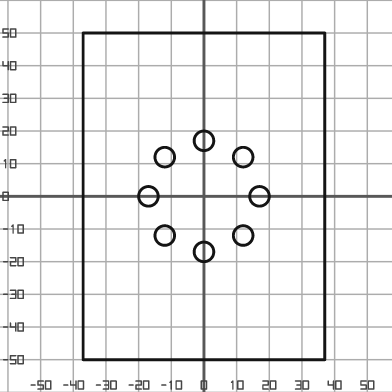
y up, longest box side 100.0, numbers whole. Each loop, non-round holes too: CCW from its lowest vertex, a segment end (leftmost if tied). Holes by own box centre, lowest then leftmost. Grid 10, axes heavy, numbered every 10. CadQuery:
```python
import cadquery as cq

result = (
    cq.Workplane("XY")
    .moveTo(-37.0, -50.0)
    .lineTo(37.0, -50.0)
    .lineTo(37.0, 50.0)
    .lineTo(-37.0, 50.0)
    .close()
    .moveTo(0.0, -17.0)
    .circle(3.0)
    .moveTo(-12.0, -12.0)
    .circle(3.0)
    .moveTo(12.0, -12.0)
    .circle(3.0)
    .moveTo(-17.0, 0.0)
    .circle(3.0)
    .moveTo(17.0, 0.0)
    .circle(3.0)
    .moveTo(-12.0, 12.0)
    .circle(3.0)
    .moveTo(12.0, 12.0)
    .circle(3.0)
    .moveTo(0.0, 17.0)
    .circle(3.0)
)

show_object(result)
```